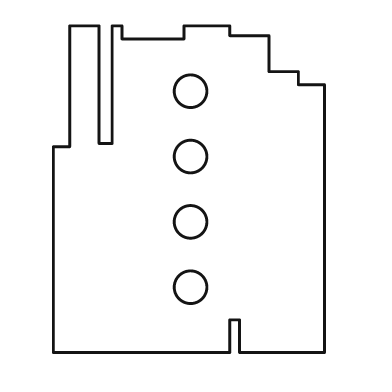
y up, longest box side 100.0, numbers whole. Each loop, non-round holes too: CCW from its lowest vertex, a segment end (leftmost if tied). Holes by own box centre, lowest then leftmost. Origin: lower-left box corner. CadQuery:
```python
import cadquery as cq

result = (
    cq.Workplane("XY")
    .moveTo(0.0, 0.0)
    .lineTo(54.0, 0.0)
    .lineTo(54.0, 10.0)
    .lineTo(57.0, 10.0)
    .lineTo(57.0, 0.0)
    .lineTo(83.0, 0.0)
    .lineTo(83.0, 82.0)
    .lineTo(75.0, 82.0)
    .lineTo(75.0, 86.0)
    .lineTo(66.0, 86.0)
    .lineTo(66.0, 97.0)
    .lineTo(54.0, 97.0)
    .lineTo(54.0, 100.0)
    .lineTo(40.0, 100.0)
    .lineTo(40.0, 96.0)
    .lineTo(21.0, 96.0)
    .lineTo(21.0, 100.0)
    .lineTo(18.0, 100.0)
    .lineTo(18.0, 64.0)
    .lineTo(14.0, 64.0)
    .lineTo(14.0, 100.0)
    .lineTo(5.0, 100.0)
    .lineTo(5.0, 63.0)
    .lineTo(0.0, 63.0)
    .close()
    .moveTo(42.0, 20.0)
    .circle(5.0)
    .moveTo(42.0, 40.0)
    .circle(5.0)
    .moveTo(42.0, 60.0)
    .circle(5.0)
    .moveTo(42.0, 80.0)
    .circle(5.0)
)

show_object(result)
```